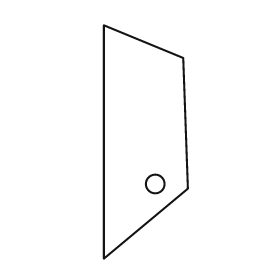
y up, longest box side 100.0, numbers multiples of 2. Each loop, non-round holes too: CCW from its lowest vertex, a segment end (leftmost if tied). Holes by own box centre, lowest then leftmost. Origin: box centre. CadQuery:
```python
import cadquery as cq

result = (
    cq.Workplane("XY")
    .moveTo(-18.0, -50.0)
    .lineTo(18.0, -20.0)
    .lineTo(16.0, 36.0)
    .lineTo(-18.0, 50.0)
    .close()
    .moveTo(4.0, -18.0)
    .circle(4.0)
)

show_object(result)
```